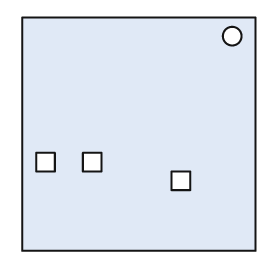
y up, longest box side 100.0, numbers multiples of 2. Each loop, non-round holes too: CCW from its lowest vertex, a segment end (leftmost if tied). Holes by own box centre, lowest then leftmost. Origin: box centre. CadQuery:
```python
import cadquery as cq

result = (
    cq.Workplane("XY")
    .moveTo(-50.0, -50.0)
    .lineTo(50.0, -50.0)
    .lineTo(50.0, 50.0)
    .lineTo(-50.0, 50.0)
    .close()
    .moveTo(14.0, -24.0)
    .lineTo(22.0, -24.0)
    .lineTo(22.0, -16.0)
    .lineTo(14.0, -16.0)
    .close()
    .moveTo(-44.0, -16.0)
    .lineTo(-36.0, -16.0)
    .lineTo(-36.0, -8.0)
    .lineTo(-44.0, -8.0)
    .close()
    .moveTo(-24.0, -16.0)
    .lineTo(-16.0, -16.0)
    .lineTo(-16.0, -8.0)
    .lineTo(-24.0, -8.0)
    .close()
    .moveTo(40.0, 42.0)
    .circle(4.0)
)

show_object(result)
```